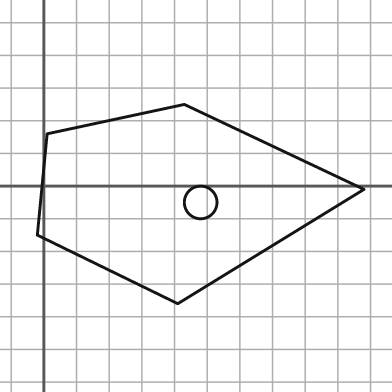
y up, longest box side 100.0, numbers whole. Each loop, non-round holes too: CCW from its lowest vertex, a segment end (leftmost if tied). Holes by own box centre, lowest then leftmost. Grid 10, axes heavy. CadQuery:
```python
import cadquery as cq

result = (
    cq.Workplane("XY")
    .moveTo(41.0, -36.0)
    .lineTo(98.0, -1.0)
    .lineTo(43.0, 25.0)
    .lineTo(1.0, 16.0)
    .lineTo(-2.0, -15.0)
    .close()
    .moveTo(48.0, -5.0)
    .circle(5.0)
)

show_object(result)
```